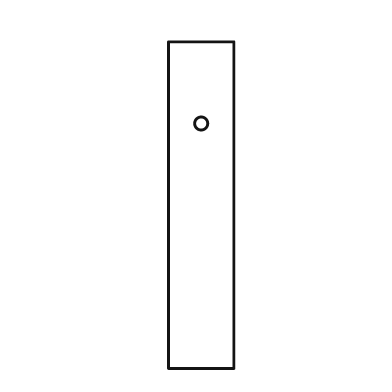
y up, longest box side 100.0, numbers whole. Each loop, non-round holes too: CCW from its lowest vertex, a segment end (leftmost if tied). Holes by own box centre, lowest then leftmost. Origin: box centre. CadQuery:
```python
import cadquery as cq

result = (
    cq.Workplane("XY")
    .moveTo(-10.0, -50.0)
    .lineTo(10.0, -50.0)
    .lineTo(10.0, 50.0)
    .lineTo(-10.0, 50.0)
    .close()
    .moveTo(0.0, 25.0)
    .circle(2.0)
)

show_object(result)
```